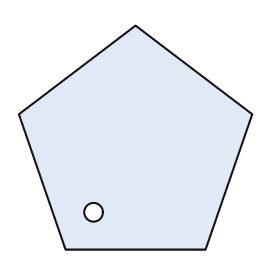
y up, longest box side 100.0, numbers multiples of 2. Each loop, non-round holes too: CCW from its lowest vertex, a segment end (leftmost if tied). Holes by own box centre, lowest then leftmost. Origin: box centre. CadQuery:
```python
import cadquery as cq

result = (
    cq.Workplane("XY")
    .moveTo(-30.0, -48.0)
    .lineTo(30.0, -48.0)
    .lineTo(50.0, 10.0)
    .lineTo(0.0, 48.0)
    .lineTo(-50.0, 10.0)
    .close()
    .moveTo(-18.0, -32.0)
    .circle(4.0)
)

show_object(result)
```